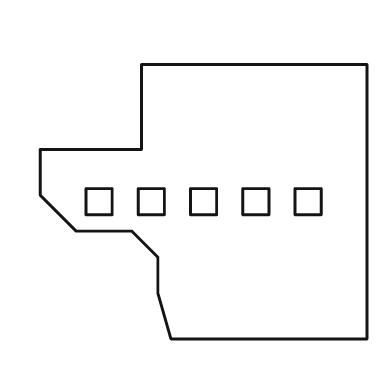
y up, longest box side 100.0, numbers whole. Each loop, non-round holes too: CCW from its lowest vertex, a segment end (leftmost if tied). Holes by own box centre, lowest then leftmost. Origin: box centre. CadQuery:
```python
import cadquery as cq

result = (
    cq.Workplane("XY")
    .moveTo(-10.0, -42.0)
    .lineTo(50.0, -42.0)
    .lineTo(50.0, 42.0)
    .lineTo(-19.0, 42.0)
    .lineTo(-19.0, 16.0)
    .lineTo(-50.0, 16.0)
    .lineTo(-50.0, 2.0)
    .lineTo(-39.0, -9.0)
    .lineTo(-22.0, -9.0)
    .lineTo(-14.0, -17.0)
    .lineTo(-14.0, -28.0)
    .close()
    .moveTo(-36.0, -4.0)
    .lineTo(-28.0, -4.0)
    .lineTo(-28.0, 4.0)
    .lineTo(-36.0, 4.0)
    .close()
    .moveTo(-20.0, -4.0)
    .lineTo(-12.0, -4.0)
    .lineTo(-12.0, 4.0)
    .lineTo(-20.0, 4.0)
    .close()
    .moveTo(-4.0, -4.0)
    .lineTo(4.0, -4.0)
    .lineTo(4.0, 4.0)
    .lineTo(-4.0, 4.0)
    .close()
    .moveTo(12.0, -4.0)
    .lineTo(20.0, -4.0)
    .lineTo(20.0, 4.0)
    .lineTo(12.0, 4.0)
    .close()
    .moveTo(28.0, -4.0)
    .lineTo(36.0, -4.0)
    .lineTo(36.0, 4.0)
    .lineTo(28.0, 4.0)
    .close()
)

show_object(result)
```